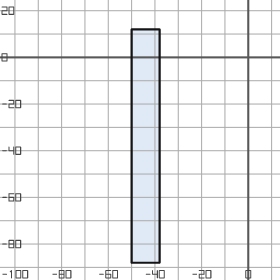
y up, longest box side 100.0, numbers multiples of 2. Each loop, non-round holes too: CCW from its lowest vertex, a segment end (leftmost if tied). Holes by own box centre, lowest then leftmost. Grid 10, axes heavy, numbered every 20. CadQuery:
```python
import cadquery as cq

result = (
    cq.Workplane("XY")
    .moveTo(-50.0, -88.0)
    .lineTo(-38.0, -88.0)
    .lineTo(-38.0, 12.0)
    .lineTo(-50.0, 12.0)
    .close()
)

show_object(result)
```